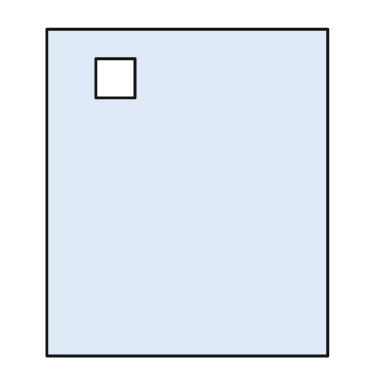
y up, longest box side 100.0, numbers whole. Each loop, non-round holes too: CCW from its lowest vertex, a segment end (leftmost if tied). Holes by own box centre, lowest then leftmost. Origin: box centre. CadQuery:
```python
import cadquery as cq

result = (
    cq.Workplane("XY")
    .moveTo(-43.0, -50.0)
    .lineTo(43.0, -50.0)
    .lineTo(43.0, 50.0)
    .lineTo(-43.0, 50.0)
    .close()
    .moveTo(-28.0, 29.0)
    .lineTo(-16.0, 29.0)
    .lineTo(-16.0, 41.0)
    .lineTo(-28.0, 41.0)
    .close()
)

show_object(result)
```